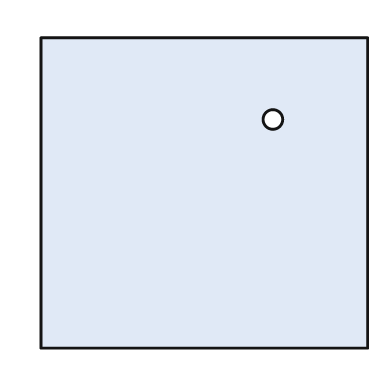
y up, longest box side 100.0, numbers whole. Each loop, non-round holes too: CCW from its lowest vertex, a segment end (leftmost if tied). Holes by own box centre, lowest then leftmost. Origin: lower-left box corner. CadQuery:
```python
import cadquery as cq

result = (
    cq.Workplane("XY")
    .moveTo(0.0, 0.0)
    .lineTo(100.0, 0.0)
    .lineTo(100.0, 95.0)
    .lineTo(0.0, 95.0)
    .close()
    .moveTo(71.0, 70.0)
    .circle(3.0)
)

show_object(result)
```